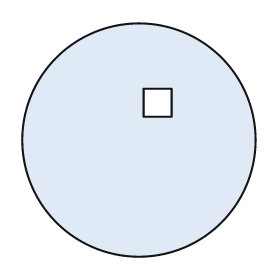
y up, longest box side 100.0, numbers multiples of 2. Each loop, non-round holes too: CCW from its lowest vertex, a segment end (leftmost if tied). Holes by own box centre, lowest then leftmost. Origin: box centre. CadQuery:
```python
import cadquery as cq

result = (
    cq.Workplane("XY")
    .moveTo(0.0, 0.0)
    .circle(50.0)
    .moveTo(2.0, 10.0)
    .lineTo(14.0, 10.0)
    .lineTo(14.0, 22.0)
    .lineTo(2.0, 22.0)
    .close()
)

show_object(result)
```